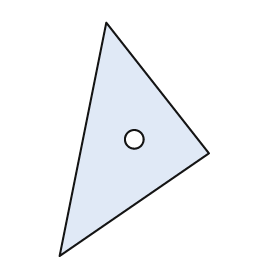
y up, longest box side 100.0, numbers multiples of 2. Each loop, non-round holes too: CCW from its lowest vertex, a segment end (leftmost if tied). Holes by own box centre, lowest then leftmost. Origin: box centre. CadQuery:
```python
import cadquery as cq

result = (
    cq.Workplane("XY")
    .moveTo(-32.0, -50.0)
    .lineTo(32.0, -6.0)
    .lineTo(-12.0, 50.0)
    .close()
    .moveTo(0.0, 0.0)
    .circle(4.0)
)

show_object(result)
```